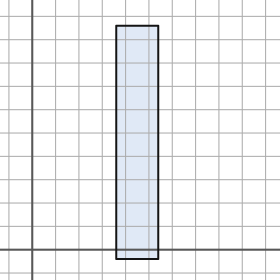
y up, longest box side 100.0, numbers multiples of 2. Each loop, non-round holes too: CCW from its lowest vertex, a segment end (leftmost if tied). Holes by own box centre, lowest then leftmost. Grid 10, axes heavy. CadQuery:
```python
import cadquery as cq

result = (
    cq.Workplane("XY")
    .moveTo(36.0, -4.0)
    .lineTo(54.0, -4.0)
    .lineTo(54.0, 96.0)
    .lineTo(36.0, 96.0)
    .close()
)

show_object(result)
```